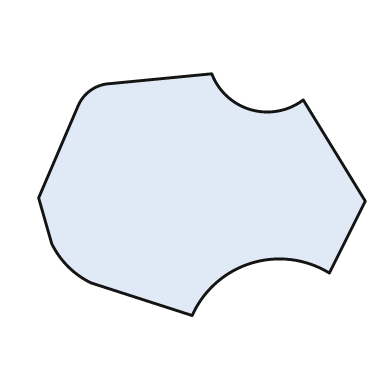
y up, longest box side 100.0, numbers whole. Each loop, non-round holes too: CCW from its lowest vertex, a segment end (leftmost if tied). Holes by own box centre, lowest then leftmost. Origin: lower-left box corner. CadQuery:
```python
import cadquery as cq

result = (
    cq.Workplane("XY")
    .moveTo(47.0, 0.0)
    .threePointArc((65.0, 16.0), (89.0, 13.0))
    .lineTo(100.0, 35.0)
    .lineTo(81.0, 66.0)
    .threePointArc((65.0, 63.0), (53.0, 74.0))
    .lineTo(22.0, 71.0)
    .threePointArc((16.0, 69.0), (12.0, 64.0))
    .lineTo(0.0, 36.0)
    .lineTo(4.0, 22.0)
    .threePointArc((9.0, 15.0), (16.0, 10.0))
    .close()
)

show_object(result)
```